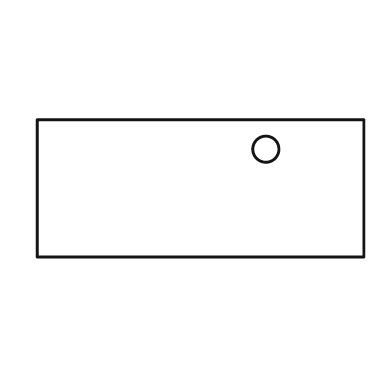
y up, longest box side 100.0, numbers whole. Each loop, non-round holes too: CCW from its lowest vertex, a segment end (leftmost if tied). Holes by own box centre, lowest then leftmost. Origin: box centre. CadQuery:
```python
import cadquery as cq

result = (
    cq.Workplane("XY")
    .moveTo(-50.0, -21.0)
    .lineTo(50.0, -21.0)
    .lineTo(50.0, 21.0)
    .lineTo(-50.0, 21.0)
    .close()
    .moveTo(20.0, 12.0)
    .circle(4.0)
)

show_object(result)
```